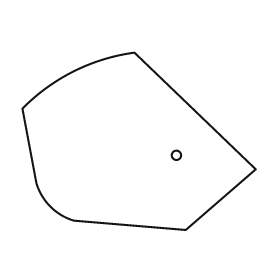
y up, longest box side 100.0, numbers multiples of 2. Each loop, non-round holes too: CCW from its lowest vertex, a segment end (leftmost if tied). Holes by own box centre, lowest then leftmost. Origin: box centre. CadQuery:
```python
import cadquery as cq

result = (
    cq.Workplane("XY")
    .moveTo(20.0, -38.0)
    .lineTo(50.0, -12.0)
    .lineTo(-2.0, 38.0)
    .threePointArc((-28.0, 30.0), (-50.0, 14.0))
    .lineTo(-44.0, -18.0)
    .threePointArc((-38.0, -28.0), (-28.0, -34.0))
    .close()
    .moveTo(16.0, -6.0)
    .circle(2.0)
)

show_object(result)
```